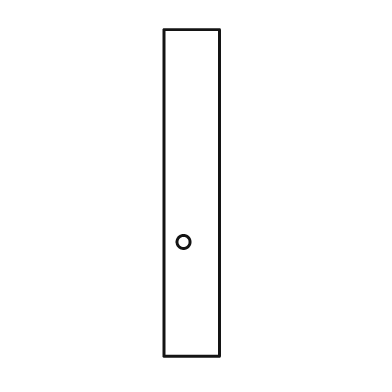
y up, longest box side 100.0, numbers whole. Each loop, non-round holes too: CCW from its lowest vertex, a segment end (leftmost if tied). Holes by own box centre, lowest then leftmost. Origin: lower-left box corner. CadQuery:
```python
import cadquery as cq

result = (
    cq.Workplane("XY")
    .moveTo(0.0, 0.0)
    .lineTo(17.0, 0.0)
    .lineTo(17.0, 100.0)
    .lineTo(0.0, 100.0)
    .close()
    .moveTo(6.0, 35.0)
    .circle(2.0)
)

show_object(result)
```